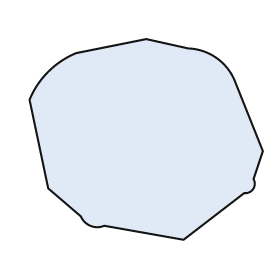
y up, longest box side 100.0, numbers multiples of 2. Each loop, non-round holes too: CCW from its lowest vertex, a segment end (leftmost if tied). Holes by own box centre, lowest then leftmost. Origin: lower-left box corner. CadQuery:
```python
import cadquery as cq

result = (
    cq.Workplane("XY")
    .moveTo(66.0, 0.0)
    .lineTo(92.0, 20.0)
    .threePointArc((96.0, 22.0), (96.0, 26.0))
    .lineTo(100.0, 38.0)
    .lineTo(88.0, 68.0)
    .threePointArc((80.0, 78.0), (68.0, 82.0))
    .lineTo(50.0, 86.0)
    .lineTo(20.0, 80.0)
    .threePointArc((8.0, 72.0), (0.0, 60.0))
    .lineTo(8.0, 22.0)
    .lineTo(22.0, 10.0)
    .threePointArc((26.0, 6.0), (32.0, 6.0))
    .close()
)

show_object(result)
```